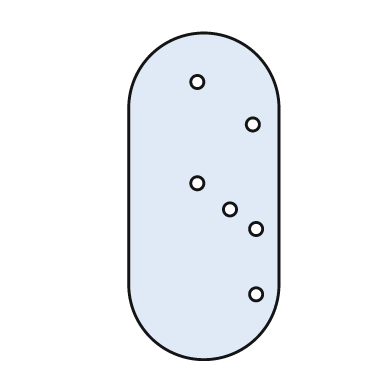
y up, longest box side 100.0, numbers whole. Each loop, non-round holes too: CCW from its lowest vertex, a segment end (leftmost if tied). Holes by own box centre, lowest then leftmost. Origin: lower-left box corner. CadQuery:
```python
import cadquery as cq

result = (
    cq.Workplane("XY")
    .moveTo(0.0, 23.0)
    .threePointArc((23.0, 0.0), (46.0, 23.0))
    .lineTo(46.0, 77.0)
    .threePointArc((23.0, 100.0), (0.0, 77.0))
    .close()
    .moveTo(39.0, 20.0)
    .circle(2.0)
    .moveTo(39.0, 40.0)
    .circle(2.0)
    .moveTo(31.0, 46.0)
    .circle(2.0)
    .moveTo(21.0, 54.0)
    .circle(2.0)
    .moveTo(38.0, 72.0)
    .circle(2.0)
    .moveTo(21.0, 85.0)
    .circle(2.0)
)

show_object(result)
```